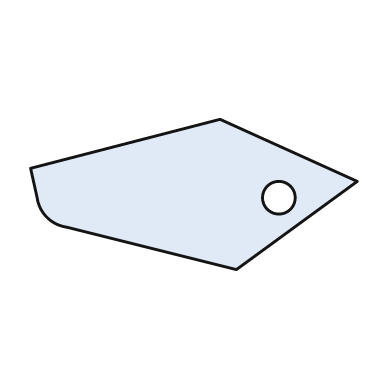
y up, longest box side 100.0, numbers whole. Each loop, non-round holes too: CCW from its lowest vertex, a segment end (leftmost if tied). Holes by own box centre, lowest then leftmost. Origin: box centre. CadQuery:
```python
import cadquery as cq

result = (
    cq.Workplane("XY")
    .moveTo(13.0, -23.0)
    .lineTo(50.0, 4.0)
    .lineTo(8.0, 23.0)
    .lineTo(-50.0, 8.0)
    .lineTo(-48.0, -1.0)
    .threePointArc((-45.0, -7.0), (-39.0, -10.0))
    .close()
    .moveTo(26.0, -1.0)
    .circle(5.0)
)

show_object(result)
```